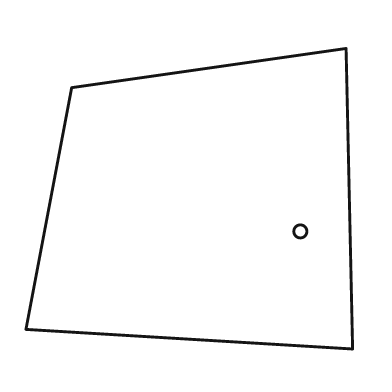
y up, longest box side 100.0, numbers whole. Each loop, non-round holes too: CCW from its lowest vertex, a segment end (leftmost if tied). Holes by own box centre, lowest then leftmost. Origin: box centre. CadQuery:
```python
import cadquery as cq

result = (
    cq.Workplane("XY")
    .moveTo(50.0, -46.0)
    .lineTo(48.0, 46.0)
    .lineTo(-36.0, 34.0)
    .lineTo(-50.0, -40.0)
    .close()
    .moveTo(34.0, -10.0)
    .circle(2.0)
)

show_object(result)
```